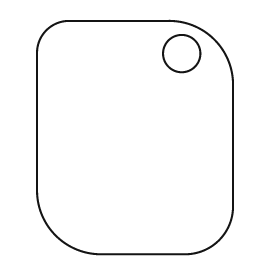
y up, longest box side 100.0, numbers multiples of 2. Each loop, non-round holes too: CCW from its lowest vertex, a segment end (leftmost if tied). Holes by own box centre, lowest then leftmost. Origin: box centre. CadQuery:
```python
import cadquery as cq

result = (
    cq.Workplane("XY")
    .moveTo(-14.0, -50.0)
    .lineTo(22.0, -50.0)
    .threePointArc((36.0, -44.0), (42.0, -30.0))
    .lineTo(42.0, 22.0)
    .threePointArc((34.0, 42.0), (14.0, 50.0))
    .lineTo(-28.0, 50.0)
    .threePointArc((-38.0, 46.0), (-42.0, 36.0))
    .lineTo(-42.0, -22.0)
    .threePointArc((-34.0, -42.0), (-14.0, -50.0))
    .close()
    .moveTo(20.0, 36.0)
    .circle(8.0)
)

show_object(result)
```